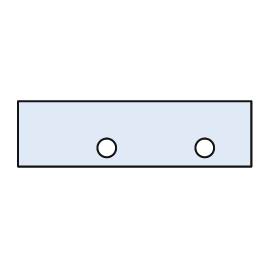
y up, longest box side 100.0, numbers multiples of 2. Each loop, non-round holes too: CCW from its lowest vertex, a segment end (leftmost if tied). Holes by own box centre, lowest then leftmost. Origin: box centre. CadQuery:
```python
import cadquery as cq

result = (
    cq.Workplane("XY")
    .moveTo(-50.0, -14.0)
    .lineTo(50.0, -14.0)
    .lineTo(50.0, 14.0)
    .lineTo(-50.0, 14.0)
    .close()
    .moveTo(-12.0, -6.0)
    .circle(4.0)
    .moveTo(30.0, -6.0)
    .circle(4.0)
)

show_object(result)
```